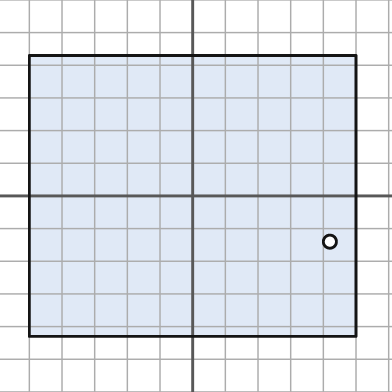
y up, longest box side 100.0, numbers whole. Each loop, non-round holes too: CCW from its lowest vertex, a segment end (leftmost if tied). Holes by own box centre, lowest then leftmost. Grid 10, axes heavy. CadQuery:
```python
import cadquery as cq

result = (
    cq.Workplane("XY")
    .moveTo(-50.0, -43.0)
    .lineTo(50.0, -43.0)
    .lineTo(50.0, 43.0)
    .lineTo(-50.0, 43.0)
    .close()
    .moveTo(42.0, -14.0)
    .circle(2.0)
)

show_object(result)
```